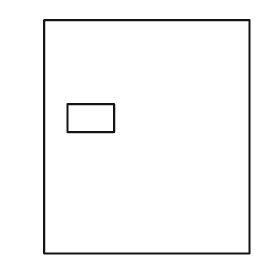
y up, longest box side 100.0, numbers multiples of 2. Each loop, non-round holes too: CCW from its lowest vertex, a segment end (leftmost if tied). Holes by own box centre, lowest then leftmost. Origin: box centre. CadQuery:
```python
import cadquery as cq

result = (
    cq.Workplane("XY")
    .moveTo(-44.0, -50.0)
    .lineTo(44.0, -50.0)
    .lineTo(44.0, 50.0)
    .lineTo(-44.0, 50.0)
    .close()
    .moveTo(-34.0, 2.0)
    .lineTo(-14.0, 2.0)
    .lineTo(-14.0, 14.0)
    .lineTo(-34.0, 14.0)
    .close()
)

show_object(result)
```